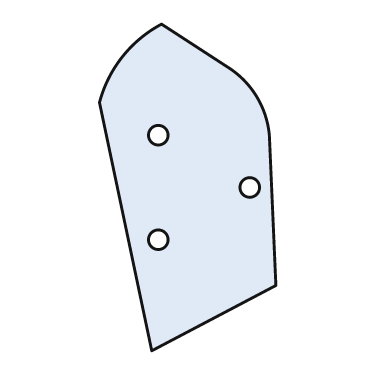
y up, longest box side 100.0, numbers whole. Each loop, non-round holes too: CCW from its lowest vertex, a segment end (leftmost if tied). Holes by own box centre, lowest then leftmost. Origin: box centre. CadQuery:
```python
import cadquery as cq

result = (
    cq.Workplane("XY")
    .moveTo(-11.0, -50.0)
    .lineTo(27.0, -30.0)
    .lineTo(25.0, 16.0)
    .threePointArc((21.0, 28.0), (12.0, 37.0))
    .lineTo(-8.0, 50.0)
    .threePointArc((-20.0, 40.0), (-27.0, 26.0))
    .close()
    .moveTo(-9.0, -16.0)
    .circle(3.0)
    .moveTo(19.0, 0.0)
    .circle(3.0)
    .moveTo(-9.0, 16.0)
    .circle(3.0)
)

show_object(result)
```